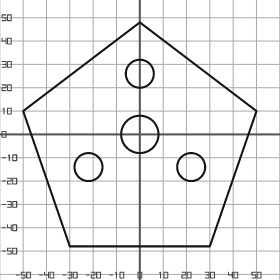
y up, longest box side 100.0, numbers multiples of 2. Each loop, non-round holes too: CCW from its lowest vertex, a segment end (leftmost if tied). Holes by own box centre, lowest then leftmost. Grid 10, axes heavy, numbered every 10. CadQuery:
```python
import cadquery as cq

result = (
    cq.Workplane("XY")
    .moveTo(-30.0, -48.0)
    .lineTo(30.0, -48.0)
    .lineTo(50.0, 10.0)
    .lineTo(0.0, 48.0)
    .lineTo(-50.0, 10.0)
    .close()
    .moveTo(-22.0, -14.0)
    .circle(6.0)
    .moveTo(22.0, -14.0)
    .circle(6.0)
    .moveTo(0.0, 0.0)
    .circle(8.0)
    .moveTo(0.0, 26.0)
    .circle(6.0)
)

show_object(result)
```